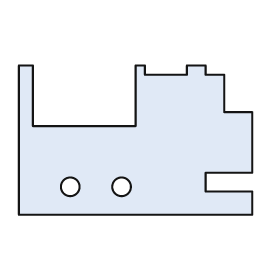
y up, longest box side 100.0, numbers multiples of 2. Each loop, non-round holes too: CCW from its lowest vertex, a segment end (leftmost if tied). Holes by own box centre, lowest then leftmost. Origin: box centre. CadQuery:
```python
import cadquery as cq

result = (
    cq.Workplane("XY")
    .moveTo(-50.0, -32.0)
    .lineTo(50.0, -32.0)
    .lineTo(50.0, -22.0)
    .lineTo(30.0, -22.0)
    .lineTo(30.0, -14.0)
    .lineTo(50.0, -14.0)
    .lineTo(50.0, 12.0)
    .lineTo(38.0, 12.0)
    .lineTo(38.0, 28.0)
    .lineTo(30.0, 28.0)
    .lineTo(30.0, 32.0)
    .lineTo(22.0, 32.0)
    .lineTo(22.0, 28.0)
    .lineTo(4.0, 28.0)
    .lineTo(4.0, 32.0)
    .lineTo(0.0, 32.0)
    .lineTo(0.0, 6.0)
    .lineTo(-44.0, 6.0)
    .lineTo(-44.0, 32.0)
    .lineTo(-50.0, 32.0)
    .close()
    .moveTo(-28.0, -20.0)
    .circle(4.0)
    .moveTo(-6.0, -20.0)
    .circle(4.0)
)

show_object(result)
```